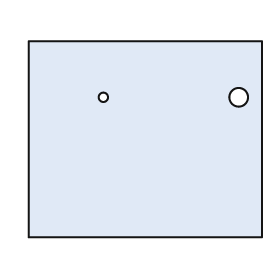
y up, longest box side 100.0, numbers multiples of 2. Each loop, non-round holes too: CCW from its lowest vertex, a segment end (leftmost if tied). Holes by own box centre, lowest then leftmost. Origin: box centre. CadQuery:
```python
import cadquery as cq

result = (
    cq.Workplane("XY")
    .moveTo(-50.0, -42.0)
    .lineTo(50.0, -42.0)
    .lineTo(50.0, 42.0)
    .lineTo(-50.0, 42.0)
    .close()
    .moveTo(-18.0, 18.0)
    .circle(2.0)
    .moveTo(40.0, 18.0)
    .circle(4.0)
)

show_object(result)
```